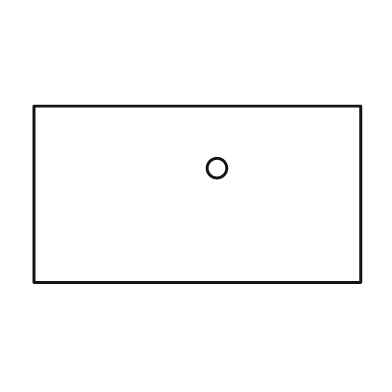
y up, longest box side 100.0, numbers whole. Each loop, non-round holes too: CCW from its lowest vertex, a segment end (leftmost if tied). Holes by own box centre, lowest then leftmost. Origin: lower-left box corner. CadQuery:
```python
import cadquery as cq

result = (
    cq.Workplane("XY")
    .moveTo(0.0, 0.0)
    .lineTo(100.0, 0.0)
    .lineTo(100.0, 54.0)
    .lineTo(0.0, 54.0)
    .close()
    .moveTo(56.0, 35.0)
    .circle(3.0)
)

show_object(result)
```